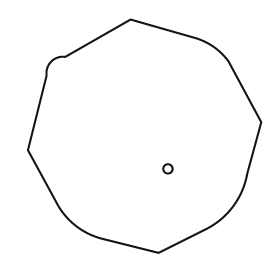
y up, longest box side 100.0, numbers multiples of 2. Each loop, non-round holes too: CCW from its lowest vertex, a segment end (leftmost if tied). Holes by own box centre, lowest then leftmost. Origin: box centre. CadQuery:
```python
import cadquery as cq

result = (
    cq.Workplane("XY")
    .moveTo(6.0, -50.0)
    .lineTo(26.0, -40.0)
    .threePointArc((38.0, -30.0), (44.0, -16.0))
    .lineTo(50.0, 6.0)
    .lineTo(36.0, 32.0)
    .threePointArc((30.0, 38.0), (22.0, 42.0))
    .lineTo(-6.0, 50.0)
    .lineTo(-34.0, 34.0)
    .threePointArc((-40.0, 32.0), (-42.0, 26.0))
    .lineTo(-50.0, -6.0)
    .lineTo(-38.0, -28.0)
    .threePointArc((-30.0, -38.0), (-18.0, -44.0))
    .close()
    .moveTo(10.0, -14.0)
    .circle(2.0)
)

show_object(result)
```